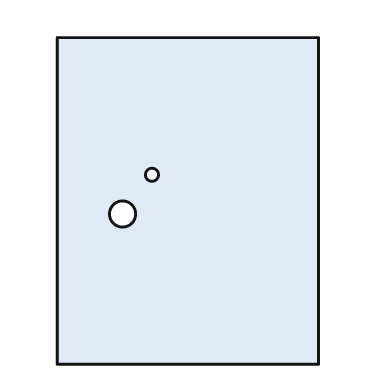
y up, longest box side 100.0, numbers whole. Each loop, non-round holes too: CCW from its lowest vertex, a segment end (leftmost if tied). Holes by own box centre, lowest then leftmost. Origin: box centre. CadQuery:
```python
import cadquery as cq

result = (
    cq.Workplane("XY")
    .moveTo(-40.0, -50.0)
    .lineTo(40.0, -50.0)
    .lineTo(40.0, 50.0)
    .lineTo(-40.0, 50.0)
    .close()
    .moveTo(-20.0, -4.0)
    .circle(4.0)
    .moveTo(-11.0, 8.0)
    .circle(2.0)
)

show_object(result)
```